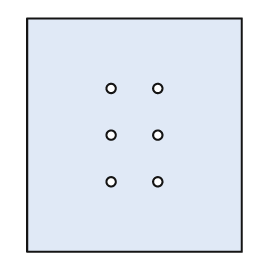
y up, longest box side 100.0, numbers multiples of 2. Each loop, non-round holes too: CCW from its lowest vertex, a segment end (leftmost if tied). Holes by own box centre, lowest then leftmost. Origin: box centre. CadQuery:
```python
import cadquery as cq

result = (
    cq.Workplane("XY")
    .moveTo(-46.0, -50.0)
    .lineTo(46.0, -50.0)
    .lineTo(46.0, 50.0)
    .lineTo(-46.0, 50.0)
    .close()
    .moveTo(-10.0, -20.0)
    .circle(2.0)
    .moveTo(10.0, -20.0)
    .circle(2.0)
    .moveTo(-10.0, 0.0)
    .circle(2.0)
    .moveTo(10.0, 0.0)
    .circle(2.0)
    .moveTo(-10.0, 20.0)
    .circle(2.0)
    .moveTo(10.0, 20.0)
    .circle(2.0)
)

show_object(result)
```